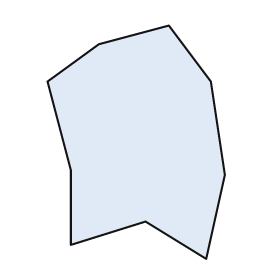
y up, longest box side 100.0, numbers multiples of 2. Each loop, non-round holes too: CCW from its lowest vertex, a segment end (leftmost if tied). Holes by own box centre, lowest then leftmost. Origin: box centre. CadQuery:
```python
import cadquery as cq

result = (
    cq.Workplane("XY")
    .moveTo(30.0, -50.0)
    .lineTo(38.0, -14.0)
    .lineTo(32.0, 26.0)
    .lineTo(14.0, 50.0)
    .lineTo(-16.0, 42.0)
    .lineTo(-38.0, 26.0)
    .lineTo(-28.0, -12.0)
    .lineTo(-28.0, -44.0)
    .lineTo(4.0, -34.0)
    .close()
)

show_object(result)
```